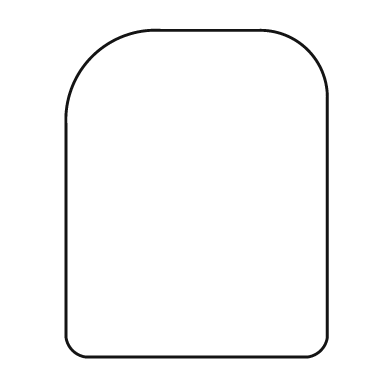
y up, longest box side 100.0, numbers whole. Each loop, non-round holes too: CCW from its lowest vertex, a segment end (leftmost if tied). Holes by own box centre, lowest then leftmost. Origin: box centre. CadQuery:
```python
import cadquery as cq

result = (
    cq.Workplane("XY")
    .moveTo(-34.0, -50.0)
    .lineTo(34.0, -50.0)
    .threePointArc((38.0, -48.0), (40.0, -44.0))
    .lineTo(40.0, 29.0)
    .threePointArc((34.0, 44.0), (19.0, 50.0))
    .lineTo(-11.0, 50.0)
    .threePointArc((-32.0, 42.0), (-40.0, 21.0))
    .lineTo(-40.0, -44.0)
    .threePointArc((-38.0, -48.0), (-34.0, -50.0))
    .close()
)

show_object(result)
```